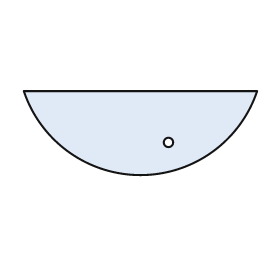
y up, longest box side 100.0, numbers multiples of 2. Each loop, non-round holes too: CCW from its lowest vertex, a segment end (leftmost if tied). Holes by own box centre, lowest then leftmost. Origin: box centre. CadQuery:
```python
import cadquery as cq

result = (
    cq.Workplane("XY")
    .moveTo(-50.0, 18.0)
    .threePointArc((0.0, -18.0), (50.0, 18.0))
    .close()
    .moveTo(12.0, -4.0)
    .circle(2.0)
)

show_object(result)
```